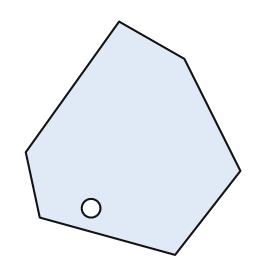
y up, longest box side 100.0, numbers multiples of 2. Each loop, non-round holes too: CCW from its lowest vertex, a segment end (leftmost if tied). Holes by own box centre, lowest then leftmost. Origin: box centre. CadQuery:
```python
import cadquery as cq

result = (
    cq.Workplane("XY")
    .moveTo(18.0, -50.0)
    .lineTo(46.0, -14.0)
    .lineTo(22.0, 34.0)
    .lineTo(-6.0, 50.0)
    .lineTo(-46.0, -6.0)
    .lineTo(-40.0, -34.0)
    .close()
    .moveTo(-18.0, -30.0)
    .circle(4.0)
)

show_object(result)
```